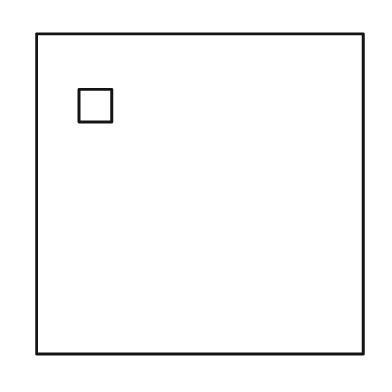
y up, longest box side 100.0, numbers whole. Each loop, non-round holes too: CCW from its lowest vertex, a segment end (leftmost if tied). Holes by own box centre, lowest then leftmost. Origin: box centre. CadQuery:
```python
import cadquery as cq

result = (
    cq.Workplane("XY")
    .moveTo(-50.0, -49.0)
    .lineTo(50.0, -49.0)
    .lineTo(50.0, 49.0)
    .lineTo(-50.0, 49.0)
    .close()
    .moveTo(-37.0, 22.0)
    .lineTo(-27.0, 22.0)
    .lineTo(-27.0, 32.0)
    .lineTo(-37.0, 32.0)
    .close()
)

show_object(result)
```